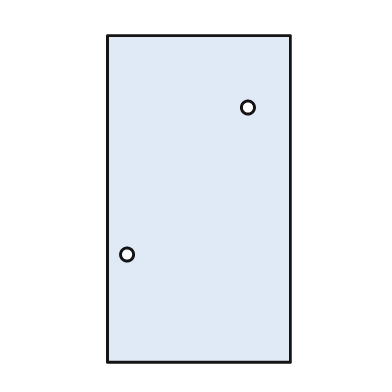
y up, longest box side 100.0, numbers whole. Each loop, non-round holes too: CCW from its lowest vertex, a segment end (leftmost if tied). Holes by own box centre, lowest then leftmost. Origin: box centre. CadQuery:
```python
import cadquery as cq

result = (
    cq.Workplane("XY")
    .moveTo(-28.0, -50.0)
    .lineTo(28.0, -50.0)
    .lineTo(28.0, 50.0)
    .lineTo(-28.0, 50.0)
    .close()
    .moveTo(-22.0, -17.0)
    .circle(2.0)
    .moveTo(15.0, 28.0)
    .circle(2.0)
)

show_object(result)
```